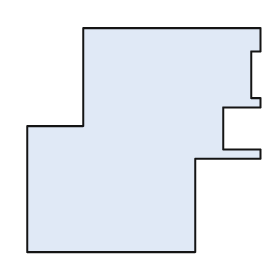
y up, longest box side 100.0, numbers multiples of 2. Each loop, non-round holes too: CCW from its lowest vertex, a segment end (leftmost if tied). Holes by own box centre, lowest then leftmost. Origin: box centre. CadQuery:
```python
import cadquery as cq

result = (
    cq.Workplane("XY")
    .moveTo(-50.0, -48.0)
    .lineTo(22.0, -48.0)
    .lineTo(22.0, -8.0)
    .lineTo(50.0, -8.0)
    .lineTo(50.0, -4.0)
    .lineTo(34.0, -4.0)
    .lineTo(34.0, 14.0)
    .lineTo(50.0, 14.0)
    .lineTo(50.0, 18.0)
    .lineTo(46.0, 18.0)
    .lineTo(46.0, 38.0)
    .lineTo(50.0, 38.0)
    .lineTo(50.0, 48.0)
    .lineTo(-26.0, 48.0)
    .lineTo(-26.0, 6.0)
    .lineTo(-50.0, 6.0)
    .close()
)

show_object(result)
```